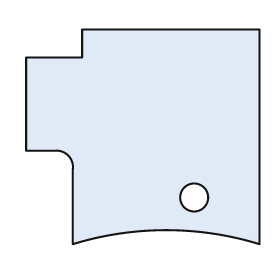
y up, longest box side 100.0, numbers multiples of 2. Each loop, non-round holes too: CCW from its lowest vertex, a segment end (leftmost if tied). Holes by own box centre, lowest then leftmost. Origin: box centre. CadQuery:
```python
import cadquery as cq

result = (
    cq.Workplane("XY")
    .moveTo(-30.0, -46.0)
    .threePointArc((10.0, -40.0), (50.0, -46.0))
    .lineTo(50.0, 46.0)
    .lineTo(-26.0, 46.0)
    .lineTo(-26.0, 34.0)
    .lineTo(-50.0, 34.0)
    .lineTo(-50.0, -6.0)
    .lineTo(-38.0, -6.0)
    .threePointArc((-32.0, -8.0), (-30.0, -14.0))
    .close()
    .moveTo(22.0, -26.0)
    .circle(6.0)
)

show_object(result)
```